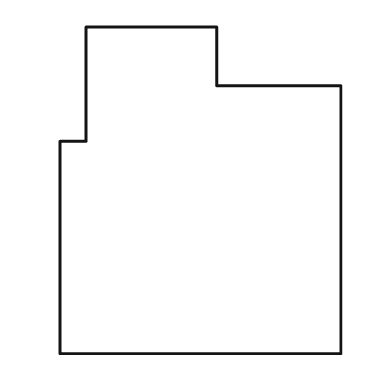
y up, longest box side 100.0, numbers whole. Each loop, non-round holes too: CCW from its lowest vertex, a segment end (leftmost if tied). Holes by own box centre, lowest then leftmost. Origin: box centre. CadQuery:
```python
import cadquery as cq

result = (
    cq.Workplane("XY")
    .moveTo(-43.0, -50.0)
    .lineTo(43.0, -50.0)
    .lineTo(43.0, 32.0)
    .lineTo(5.0, 32.0)
    .lineTo(5.0, 50.0)
    .lineTo(-35.0, 50.0)
    .lineTo(-35.0, 15.0)
    .lineTo(-43.0, 15.0)
    .close()
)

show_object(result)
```